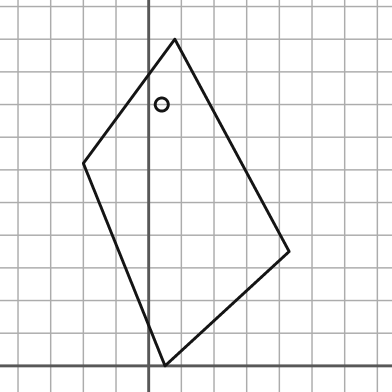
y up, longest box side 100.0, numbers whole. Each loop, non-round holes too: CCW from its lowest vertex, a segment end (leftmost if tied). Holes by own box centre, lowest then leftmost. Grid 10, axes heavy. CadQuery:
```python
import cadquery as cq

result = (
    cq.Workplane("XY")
    .moveTo(5.0, 0.0)
    .lineTo(43.0, 35.0)
    .lineTo(8.0, 100.0)
    .lineTo(-20.0, 62.0)
    .close()
    .moveTo(4.0, 80.0)
    .circle(2.0)
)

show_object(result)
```